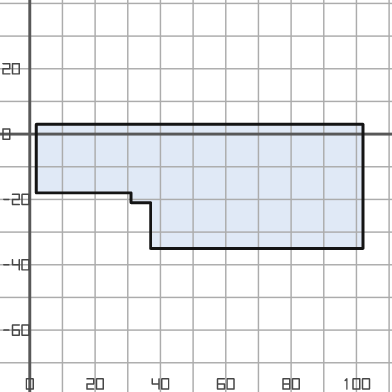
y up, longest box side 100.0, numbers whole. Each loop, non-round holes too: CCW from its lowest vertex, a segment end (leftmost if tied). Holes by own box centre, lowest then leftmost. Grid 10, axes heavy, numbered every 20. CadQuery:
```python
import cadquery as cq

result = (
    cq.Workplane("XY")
    .moveTo(37.0, -35.0)
    .lineTo(102.0, -35.0)
    .lineTo(102.0, 3.0)
    .lineTo(2.0, 3.0)
    .lineTo(2.0, -18.0)
    .lineTo(31.0, -18.0)
    .lineTo(31.0, -21.0)
    .lineTo(37.0, -21.0)
    .close()
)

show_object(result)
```